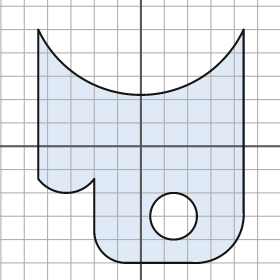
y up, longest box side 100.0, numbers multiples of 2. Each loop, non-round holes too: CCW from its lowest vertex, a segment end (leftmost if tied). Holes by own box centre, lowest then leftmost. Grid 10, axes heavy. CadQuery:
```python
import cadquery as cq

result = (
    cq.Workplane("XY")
    .moveTo(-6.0, -50.0)
    .lineTo(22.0, -50.0)
    .threePointArc((38.0, -44.0), (44.0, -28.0))
    .lineTo(44.0, 50.0)
    .threePointArc((0.0, 22.0), (-44.0, 50.0))
    .lineTo(-44.0, -14.0)
    .threePointArc((-32.0, -20.0), (-20.0, -14.0))
    .lineTo(-20.0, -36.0)
    .threePointArc((-16.0, -46.0), (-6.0, -50.0))
    .close()
    .moveTo(14.0, -30.0)
    .circle(10.0)
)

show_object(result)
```